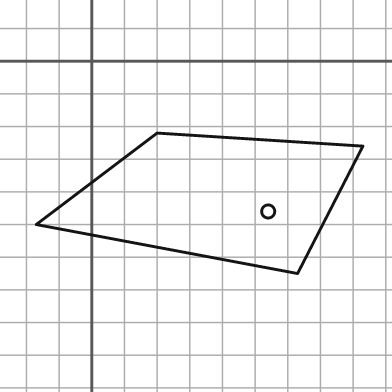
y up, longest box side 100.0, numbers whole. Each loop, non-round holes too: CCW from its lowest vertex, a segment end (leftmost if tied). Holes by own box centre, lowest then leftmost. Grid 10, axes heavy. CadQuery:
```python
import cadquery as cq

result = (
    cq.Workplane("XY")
    .moveTo(63.0, -65.0)
    .lineTo(83.0, -26.0)
    .lineTo(20.0, -22.0)
    .lineTo(-17.0, -50.0)
    .close()
    .moveTo(54.0, -46.0)
    .circle(2.0)
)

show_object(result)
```